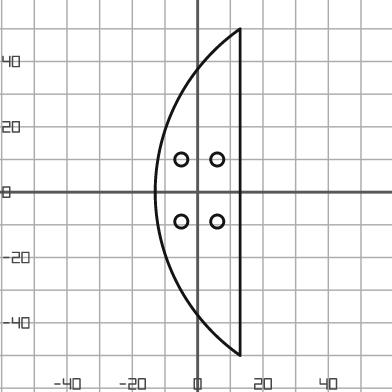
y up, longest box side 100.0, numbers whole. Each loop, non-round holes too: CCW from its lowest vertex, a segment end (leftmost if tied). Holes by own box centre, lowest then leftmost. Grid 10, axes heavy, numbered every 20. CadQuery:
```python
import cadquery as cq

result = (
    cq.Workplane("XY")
    .moveTo(13.0, -50.0)
    .lineTo(13.0, 50.0)
    .threePointArc((-13.0, 0.0), (13.0, -50.0))
    .close()
    .moveTo(-5.0, -9.0)
    .circle(2.0)
    .moveTo(6.0, -9.0)
    .circle(2.0)
    .moveTo(-5.0, 10.0)
    .circle(2.0)
    .moveTo(6.0, 10.0)
    .circle(2.0)
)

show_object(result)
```